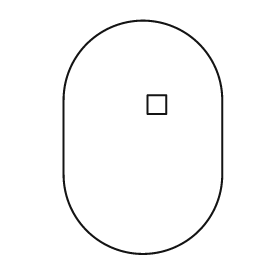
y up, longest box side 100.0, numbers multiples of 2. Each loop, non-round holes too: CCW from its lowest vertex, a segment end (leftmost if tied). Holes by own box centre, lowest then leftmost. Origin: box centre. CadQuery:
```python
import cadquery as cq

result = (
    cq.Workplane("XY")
    .moveTo(-34.0, -16.0)
    .threePointArc((0.0, -50.0), (34.0, -16.0))
    .lineTo(34.0, 16.0)
    .threePointArc((0.0, 50.0), (-34.0, 16.0))
    .close()
    .moveTo(2.0, 10.0)
    .lineTo(10.0, 10.0)
    .lineTo(10.0, 18.0)
    .lineTo(2.0, 18.0)
    .close()
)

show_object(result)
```